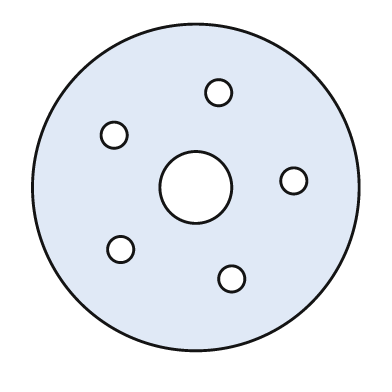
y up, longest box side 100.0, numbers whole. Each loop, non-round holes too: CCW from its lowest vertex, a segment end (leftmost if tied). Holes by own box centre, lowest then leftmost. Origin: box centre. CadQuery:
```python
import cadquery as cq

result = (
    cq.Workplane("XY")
    .moveTo(0.0, 0.0)
    .circle(50.0)
    .moveTo(11.0, -28.0)
    .circle(4.0)
    .moveTo(-23.0, -19.0)
    .circle(4.0)
    .moveTo(0.0, 0.0)
    .circle(11.0)
    .moveTo(30.0, 2.0)
    .circle(4.0)
    .moveTo(-25.0, 16.0)
    .circle(4.0)
    .moveTo(7.0, 29.0)
    .circle(4.0)
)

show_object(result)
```